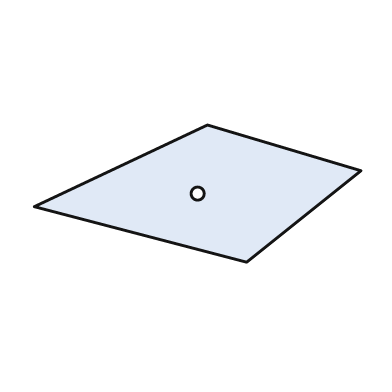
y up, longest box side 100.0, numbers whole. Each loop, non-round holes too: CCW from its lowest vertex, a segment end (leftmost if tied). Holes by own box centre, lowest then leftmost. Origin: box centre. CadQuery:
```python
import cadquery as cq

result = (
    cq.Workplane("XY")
    .moveTo(15.0, -21.0)
    .lineTo(50.0, 7.0)
    .lineTo(3.0, 21.0)
    .lineTo(-50.0, -4.0)
    .close()
    .moveTo(0.0, 0.0)
    .circle(2.0)
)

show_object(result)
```